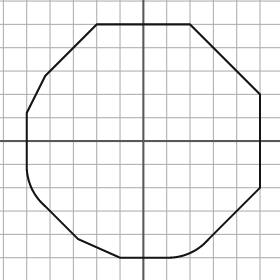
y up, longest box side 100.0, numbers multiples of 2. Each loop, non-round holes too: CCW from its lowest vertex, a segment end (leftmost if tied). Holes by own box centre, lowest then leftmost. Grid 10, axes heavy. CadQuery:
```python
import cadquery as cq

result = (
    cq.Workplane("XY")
    .moveTo(-10.0, -50.0)
    .lineTo(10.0, -50.0)
    .threePointArc((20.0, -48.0), (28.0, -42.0))
    .lineTo(50.0, -20.0)
    .lineTo(50.0, 20.0)
    .lineTo(20.0, 50.0)
    .lineTo(-20.0, 50.0)
    .lineTo(-42.0, 28.0)
    .lineTo(-50.0, 12.0)
    .lineTo(-50.0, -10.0)
    .threePointArc((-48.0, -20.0), (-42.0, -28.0))
    .lineTo(-28.0, -42.0)
    .close()
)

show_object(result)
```